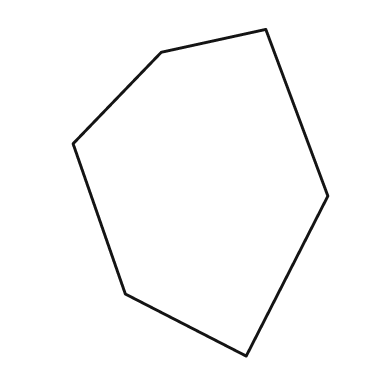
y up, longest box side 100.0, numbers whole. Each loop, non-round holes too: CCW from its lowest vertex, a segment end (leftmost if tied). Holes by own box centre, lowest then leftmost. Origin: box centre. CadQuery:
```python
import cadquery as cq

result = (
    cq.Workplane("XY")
    .moveTo(14.0, -50.0)
    .lineTo(39.0, -1.0)
    .lineTo(20.0, 50.0)
    .lineTo(-12.0, 43.0)
    .lineTo(-39.0, 15.0)
    .lineTo(-23.0, -31.0)
    .close()
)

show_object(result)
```